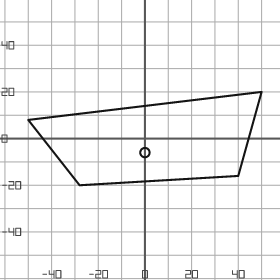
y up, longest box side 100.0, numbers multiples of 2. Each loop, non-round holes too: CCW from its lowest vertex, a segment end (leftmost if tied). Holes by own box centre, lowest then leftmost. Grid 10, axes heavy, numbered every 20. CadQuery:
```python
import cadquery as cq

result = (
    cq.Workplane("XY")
    .moveTo(-28.0, -20.0)
    .lineTo(40.0, -16.0)
    .lineTo(50.0, 20.0)
    .lineTo(-50.0, 8.0)
    .close()
    .moveTo(0.0, -6.0)
    .circle(2.0)
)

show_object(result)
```